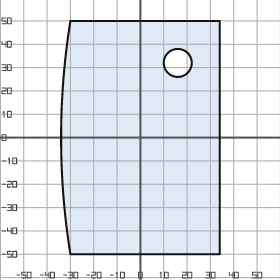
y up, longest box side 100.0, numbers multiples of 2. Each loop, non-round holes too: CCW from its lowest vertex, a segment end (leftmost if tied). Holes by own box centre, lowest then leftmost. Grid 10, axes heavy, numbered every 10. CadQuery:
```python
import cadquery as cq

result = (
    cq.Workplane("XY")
    .moveTo(-30.0, -50.0)
    .lineTo(34.0, -50.0)
    .lineTo(34.0, 50.0)
    .lineTo(-30.0, 50.0)
    .threePointArc((-34.0, 0.0), (-30.0, -50.0))
    .close()
    .moveTo(16.0, 32.0)
    .circle(6.0)
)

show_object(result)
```